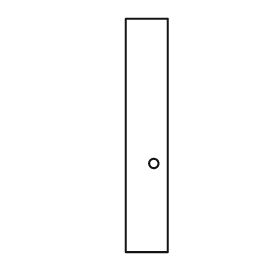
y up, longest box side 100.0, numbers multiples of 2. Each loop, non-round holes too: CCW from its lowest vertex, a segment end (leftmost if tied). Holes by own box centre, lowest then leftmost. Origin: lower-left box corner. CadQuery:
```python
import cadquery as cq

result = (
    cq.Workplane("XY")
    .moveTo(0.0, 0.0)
    .lineTo(18.0, 0.0)
    .lineTo(18.0, 100.0)
    .lineTo(0.0, 100.0)
    .close()
    .moveTo(12.0, 38.0)
    .circle(2.0)
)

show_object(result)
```